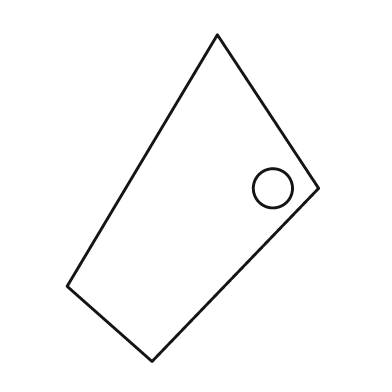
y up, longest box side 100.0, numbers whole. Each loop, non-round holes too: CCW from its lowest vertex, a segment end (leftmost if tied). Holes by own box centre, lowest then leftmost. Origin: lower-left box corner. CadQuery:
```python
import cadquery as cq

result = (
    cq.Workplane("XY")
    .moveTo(26.0, 0.0)
    .lineTo(77.0, 53.0)
    .lineTo(46.0, 100.0)
    .lineTo(0.0, 23.0)
    .close()
    .moveTo(63.0, 53.0)
    .circle(6.0)
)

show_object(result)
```